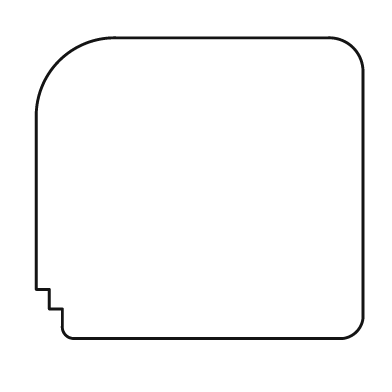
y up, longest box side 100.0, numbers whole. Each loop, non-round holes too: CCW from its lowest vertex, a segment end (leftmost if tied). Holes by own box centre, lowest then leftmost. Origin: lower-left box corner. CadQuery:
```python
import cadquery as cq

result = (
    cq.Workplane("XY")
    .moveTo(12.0, 0.0)
    .lineTo(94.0, 0.0)
    .threePointArc((98.0, 2.0), (100.0, 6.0))
    .lineTo(100.0, 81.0)
    .threePointArc((97.0, 89.0), (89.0, 92.0))
    .lineTo(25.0, 92.0)
    .threePointArc((7.0, 85.0), (0.0, 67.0))
    .lineTo(0.0, 15.0)
    .lineTo(4.0, 15.0)
    .lineTo(4.0, 9.0)
    .lineTo(8.0, 9.0)
    .lineTo(8.0, 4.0)
    .threePointArc((9.0, 1.0), (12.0, 0.0))
    .close()
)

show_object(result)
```